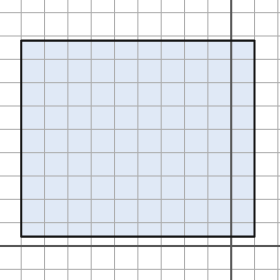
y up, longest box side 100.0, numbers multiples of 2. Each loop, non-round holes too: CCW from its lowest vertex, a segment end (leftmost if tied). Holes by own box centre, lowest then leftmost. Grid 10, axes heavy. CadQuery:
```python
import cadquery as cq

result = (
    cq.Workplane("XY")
    .moveTo(-90.0, 4.0)
    .lineTo(10.0, 4.0)
    .lineTo(10.0, 88.0)
    .lineTo(-90.0, 88.0)
    .close()
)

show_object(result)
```